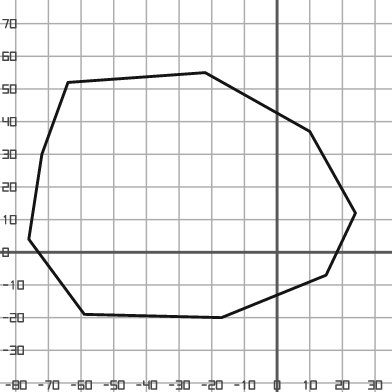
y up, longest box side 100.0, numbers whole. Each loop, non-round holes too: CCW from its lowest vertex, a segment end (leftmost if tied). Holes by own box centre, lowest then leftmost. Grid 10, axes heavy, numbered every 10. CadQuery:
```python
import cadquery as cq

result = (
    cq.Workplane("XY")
    .moveTo(-17.0, -20.0)
    .lineTo(15.0, -7.0)
    .lineTo(24.0, 12.0)
    .lineTo(10.0, 37.0)
    .lineTo(-22.0, 55.0)
    .lineTo(-64.0, 52.0)
    .lineTo(-72.0, 30.0)
    .lineTo(-76.0, 4.0)
    .lineTo(-59.0, -19.0)
    .close()
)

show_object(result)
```